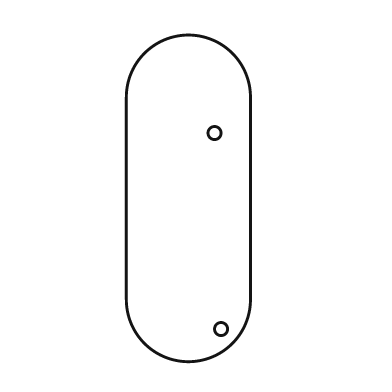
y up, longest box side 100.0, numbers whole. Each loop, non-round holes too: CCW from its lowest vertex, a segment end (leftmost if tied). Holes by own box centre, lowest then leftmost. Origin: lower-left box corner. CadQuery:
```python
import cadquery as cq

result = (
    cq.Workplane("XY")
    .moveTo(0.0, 19.0)
    .threePointArc((19.0, 0.0), (38.0, 19.0))
    .lineTo(38.0, 81.0)
    .threePointArc((19.0, 100.0), (0.0, 81.0))
    .close()
    .moveTo(29.0, 10.0)
    .circle(2.0)
    .moveTo(27.0, 70.0)
    .circle(2.0)
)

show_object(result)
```